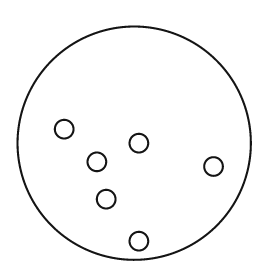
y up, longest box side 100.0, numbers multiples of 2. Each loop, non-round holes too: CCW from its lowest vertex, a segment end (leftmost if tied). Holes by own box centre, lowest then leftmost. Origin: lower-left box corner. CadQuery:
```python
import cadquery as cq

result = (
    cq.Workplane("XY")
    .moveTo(50.0, 50.0)
    .circle(50.0)
    .moveTo(52.0, 8.0)
    .circle(4.0)
    .moveTo(38.0, 26.0)
    .circle(4.0)
    .moveTo(84.0, 40.0)
    .circle(4.0)
    .moveTo(34.0, 42.0)
    .circle(4.0)
    .moveTo(52.0, 50.0)
    .circle(4.0)
    .moveTo(20.0, 56.0)
    .circle(4.0)
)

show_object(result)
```